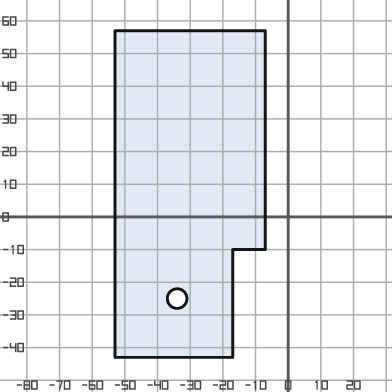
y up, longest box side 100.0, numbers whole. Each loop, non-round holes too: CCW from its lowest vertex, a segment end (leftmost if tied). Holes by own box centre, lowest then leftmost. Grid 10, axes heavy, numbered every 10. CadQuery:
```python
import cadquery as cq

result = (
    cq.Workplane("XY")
    .moveTo(-53.0, -43.0)
    .lineTo(-17.0, -43.0)
    .lineTo(-17.0, -10.0)
    .lineTo(-7.0, -10.0)
    .lineTo(-7.0, 57.0)
    .lineTo(-53.0, 57.0)
    .close()
    .moveTo(-34.0, -25.0)
    .circle(3.0)
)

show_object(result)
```